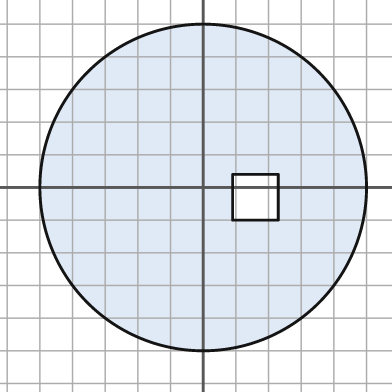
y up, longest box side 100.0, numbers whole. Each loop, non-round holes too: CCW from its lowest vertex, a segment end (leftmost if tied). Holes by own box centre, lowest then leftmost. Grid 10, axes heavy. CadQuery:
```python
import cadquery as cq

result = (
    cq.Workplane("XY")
    .moveTo(0.0, 0.0)
    .circle(50.0)
    .moveTo(9.0, -10.0)
    .lineTo(23.0, -10.0)
    .lineTo(23.0, 4.0)
    .lineTo(9.0, 4.0)
    .close()
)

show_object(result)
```